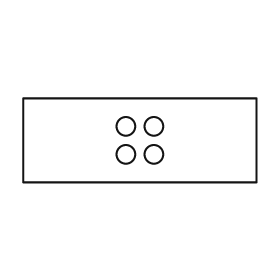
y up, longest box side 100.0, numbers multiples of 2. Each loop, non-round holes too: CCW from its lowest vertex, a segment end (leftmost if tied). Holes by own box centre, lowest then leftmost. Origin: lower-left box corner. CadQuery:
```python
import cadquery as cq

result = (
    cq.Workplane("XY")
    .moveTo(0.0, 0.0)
    .lineTo(100.0, 0.0)
    .lineTo(100.0, 36.0)
    .lineTo(0.0, 36.0)
    .close()
    .moveTo(44.0, 12.0)
    .circle(4.0)
    .moveTo(56.0, 12.0)
    .circle(4.0)
    .moveTo(44.0, 24.0)
    .circle(4.0)
    .moveTo(56.0, 24.0)
    .circle(4.0)
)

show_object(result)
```